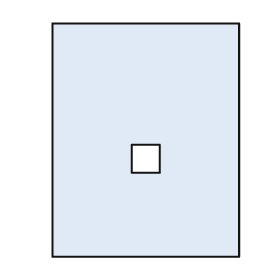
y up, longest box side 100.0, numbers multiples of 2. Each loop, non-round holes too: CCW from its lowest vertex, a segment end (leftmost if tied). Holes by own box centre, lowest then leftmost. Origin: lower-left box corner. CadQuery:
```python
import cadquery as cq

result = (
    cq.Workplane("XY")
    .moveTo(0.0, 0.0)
    .lineTo(80.0, 0.0)
    .lineTo(80.0, 100.0)
    .lineTo(0.0, 100.0)
    .close()
    .moveTo(34.0, 36.0)
    .lineTo(46.0, 36.0)
    .lineTo(46.0, 48.0)
    .lineTo(34.0, 48.0)
    .close()
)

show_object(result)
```